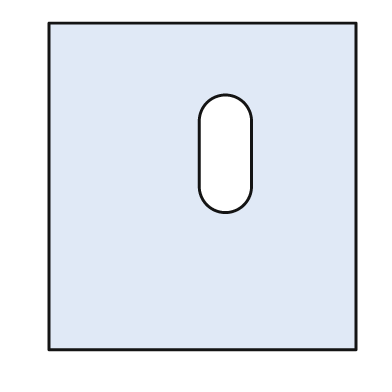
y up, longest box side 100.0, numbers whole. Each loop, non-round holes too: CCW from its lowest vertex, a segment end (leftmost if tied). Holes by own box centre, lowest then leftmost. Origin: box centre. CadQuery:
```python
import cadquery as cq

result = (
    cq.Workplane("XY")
    .moveTo(-47.0, -50.0)
    .lineTo(47.0, -50.0)
    .lineTo(47.0, 50.0)
    .lineTo(-47.0, 50.0)
    .close()
    .moveTo(-1.0, 0.0)
    .threePointArc((7.0, -8.0), (15.0, 0.0))
    .lineTo(15.0, 20.0)
    .threePointArc((7.0, 28.0), (-1.0, 20.0))
    .close()
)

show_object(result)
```